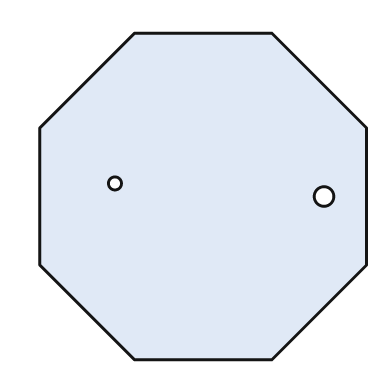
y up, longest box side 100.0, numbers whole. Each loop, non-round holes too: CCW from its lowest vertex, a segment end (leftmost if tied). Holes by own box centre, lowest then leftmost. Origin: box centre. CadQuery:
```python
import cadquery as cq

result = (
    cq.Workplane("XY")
    .moveTo(-21.0, -50.0)
    .lineTo(21.0, -50.0)
    .lineTo(50.0, -21.0)
    .lineTo(50.0, 21.0)
    .lineTo(21.0, 50.0)
    .lineTo(-21.0, 50.0)
    .lineTo(-50.0, 21.0)
    .lineTo(-50.0, -21.0)
    .close()
    .moveTo(37.0, 0.0)
    .circle(3.0)
    .moveTo(-27.0, 4.0)
    .circle(2.0)
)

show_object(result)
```